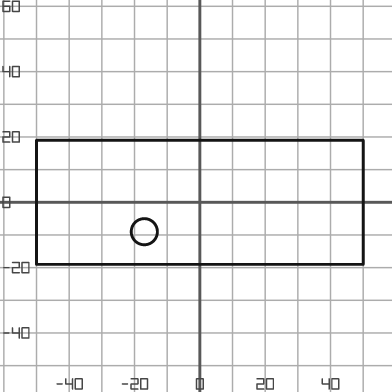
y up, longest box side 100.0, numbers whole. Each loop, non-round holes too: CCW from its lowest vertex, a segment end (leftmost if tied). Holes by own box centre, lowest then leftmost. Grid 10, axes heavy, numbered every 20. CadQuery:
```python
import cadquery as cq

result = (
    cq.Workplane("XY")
    .moveTo(-50.0, -19.0)
    .lineTo(50.0, -19.0)
    .lineTo(50.0, 19.0)
    .lineTo(-50.0, 19.0)
    .close()
    .moveTo(-17.0, -9.0)
    .circle(4.0)
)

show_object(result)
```